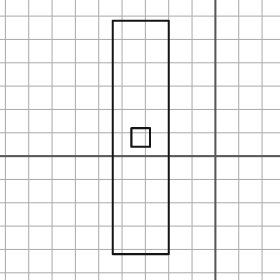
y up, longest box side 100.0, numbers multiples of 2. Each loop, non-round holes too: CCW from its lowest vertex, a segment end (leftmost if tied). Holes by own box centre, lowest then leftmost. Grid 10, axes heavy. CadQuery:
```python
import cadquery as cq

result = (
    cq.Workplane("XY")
    .moveTo(-44.0, -42.0)
    .lineTo(-20.0, -42.0)
    .lineTo(-20.0, 58.0)
    .lineTo(-44.0, 58.0)
    .close()
    .moveTo(-36.0, 4.0)
    .lineTo(-28.0, 4.0)
    .lineTo(-28.0, 12.0)
    .lineTo(-36.0, 12.0)
    .close()
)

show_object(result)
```